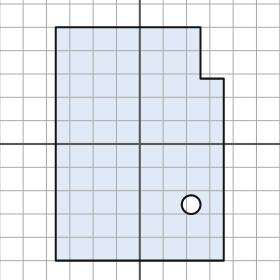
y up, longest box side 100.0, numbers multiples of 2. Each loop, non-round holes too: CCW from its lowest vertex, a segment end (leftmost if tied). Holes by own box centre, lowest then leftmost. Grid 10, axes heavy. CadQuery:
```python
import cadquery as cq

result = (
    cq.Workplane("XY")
    .moveTo(-36.0, -50.0)
    .lineTo(36.0, -50.0)
    .lineTo(36.0, 28.0)
    .lineTo(26.0, 28.0)
    .lineTo(26.0, 50.0)
    .lineTo(-36.0, 50.0)
    .close()
    .moveTo(22.0, -26.0)
    .circle(4.0)
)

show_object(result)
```